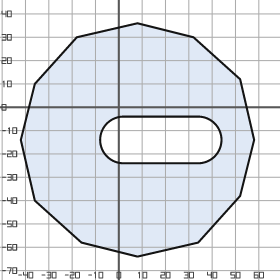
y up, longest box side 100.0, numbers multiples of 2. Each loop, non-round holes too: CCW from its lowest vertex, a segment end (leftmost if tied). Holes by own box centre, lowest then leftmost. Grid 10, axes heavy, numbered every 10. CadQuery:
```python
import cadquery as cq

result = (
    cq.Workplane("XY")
    .moveTo(8.0, -64.0)
    .lineTo(34.0, -58.0)
    .lineTo(52.0, -38.0)
    .lineTo(58.0, -14.0)
    .lineTo(52.0, 12.0)
    .lineTo(32.0, 30.0)
    .lineTo(8.0, 36.0)
    .lineTo(-18.0, 30.0)
    .lineTo(-36.0, 10.0)
    .lineTo(-42.0, -14.0)
    .lineTo(-36.0, -40.0)
    .lineTo(-16.0, -58.0)
    .close()
    .moveTo(2.0, -24.0)
    .lineTo(34.0, -24.0)
    .threePointArc((44.0, -14.0), (34.0, -4.0))
    .lineTo(2.0, -4.0)
    .threePointArc((-8.0, -14.0), (2.0, -24.0))
    .close()
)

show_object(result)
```